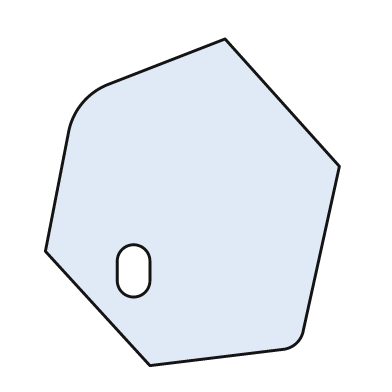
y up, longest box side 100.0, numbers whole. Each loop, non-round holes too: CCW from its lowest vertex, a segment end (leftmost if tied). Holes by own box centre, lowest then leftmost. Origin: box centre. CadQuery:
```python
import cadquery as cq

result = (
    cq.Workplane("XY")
    .moveTo(-13.0, -50.0)
    .lineTo(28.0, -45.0)
    .threePointArc((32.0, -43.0), (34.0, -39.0))
    .lineTo(45.0, 11.0)
    .lineTo(10.0, 50.0)
    .lineTo(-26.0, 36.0)
    .threePointArc((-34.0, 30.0), (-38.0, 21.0))
    .lineTo(-45.0, -15.0)
    .close()
    .moveTo(-23.0, -24.0)
    .threePointArc((-18.0, -29.0), (-13.0, -24.0))
    .lineTo(-13.0, -18.0)
    .threePointArc((-18.0, -13.0), (-23.0, -18.0))
    .close()
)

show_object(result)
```